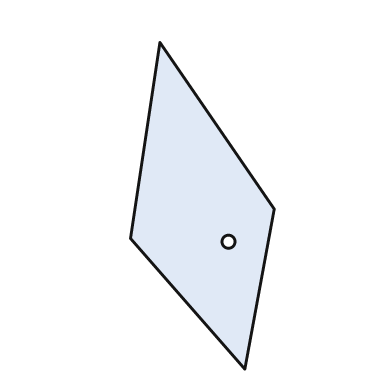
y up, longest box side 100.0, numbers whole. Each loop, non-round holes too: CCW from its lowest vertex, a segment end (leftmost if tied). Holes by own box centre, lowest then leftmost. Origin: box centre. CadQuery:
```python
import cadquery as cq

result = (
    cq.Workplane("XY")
    .moveTo(13.0, -50.0)
    .lineTo(22.0, -1.0)
    .lineTo(-13.0, 50.0)
    .lineTo(-22.0, -10.0)
    .close()
    .moveTo(8.0, -11.0)
    .circle(2.0)
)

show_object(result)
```